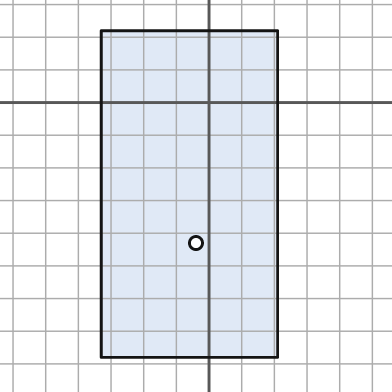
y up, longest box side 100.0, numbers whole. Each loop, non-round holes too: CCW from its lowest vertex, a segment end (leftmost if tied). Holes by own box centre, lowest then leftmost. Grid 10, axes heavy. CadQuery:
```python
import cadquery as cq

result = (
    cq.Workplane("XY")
    .moveTo(-33.0, -78.0)
    .lineTo(21.0, -78.0)
    .lineTo(21.0, 22.0)
    .lineTo(-33.0, 22.0)
    .close()
    .moveTo(-4.0, -43.0)
    .circle(2.0)
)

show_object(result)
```